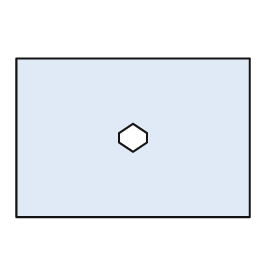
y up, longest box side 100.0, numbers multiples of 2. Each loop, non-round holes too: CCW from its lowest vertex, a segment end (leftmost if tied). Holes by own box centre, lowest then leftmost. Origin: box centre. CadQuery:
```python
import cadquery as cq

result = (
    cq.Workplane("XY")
    .moveTo(-50.0, -34.0)
    .lineTo(50.0, -34.0)
    .lineTo(50.0, 34.0)
    .lineTo(-50.0, 34.0)
    .close()
    .moveTo(0.0, -6.0)
    .lineTo(6.0, -2.0)
    .lineTo(6.0, 2.0)
    .lineTo(0.0, 6.0)
    .lineTo(-6.0, 2.0)
    .lineTo(-6.0, -2.0)
    .close()
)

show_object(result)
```